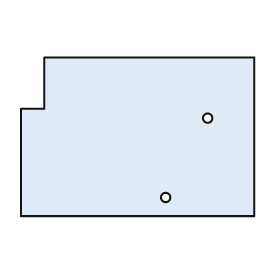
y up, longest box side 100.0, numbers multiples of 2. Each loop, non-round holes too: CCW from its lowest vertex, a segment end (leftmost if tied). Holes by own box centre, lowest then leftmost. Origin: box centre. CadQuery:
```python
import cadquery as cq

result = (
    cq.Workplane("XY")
    .moveTo(-50.0, -34.0)
    .lineTo(50.0, -34.0)
    .lineTo(50.0, 34.0)
    .lineTo(-40.0, 34.0)
    .lineTo(-40.0, 12.0)
    .lineTo(-50.0, 12.0)
    .close()
    .moveTo(12.0, -26.0)
    .circle(2.0)
    .moveTo(30.0, 8.0)
    .circle(2.0)
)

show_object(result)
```